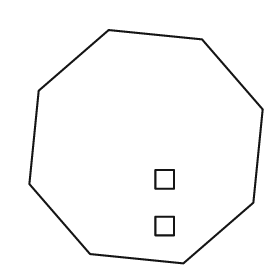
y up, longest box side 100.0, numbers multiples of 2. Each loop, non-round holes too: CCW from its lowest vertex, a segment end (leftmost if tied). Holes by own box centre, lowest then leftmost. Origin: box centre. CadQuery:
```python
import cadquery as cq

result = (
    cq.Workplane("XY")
    .moveTo(16.0, -50.0)
    .lineTo(46.0, -24.0)
    .lineTo(50.0, 16.0)
    .lineTo(24.0, 46.0)
    .lineTo(-16.0, 50.0)
    .lineTo(-46.0, 24.0)
    .lineTo(-50.0, -16.0)
    .lineTo(-24.0, -46.0)
    .close()
    .moveTo(4.0, -38.0)
    .lineTo(12.0, -38.0)
    .lineTo(12.0, -30.0)
    .lineTo(4.0, -30.0)
    .close()
    .moveTo(4.0, -18.0)
    .lineTo(12.0, -18.0)
    .lineTo(12.0, -10.0)
    .lineTo(4.0, -10.0)
    .close()
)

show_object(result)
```